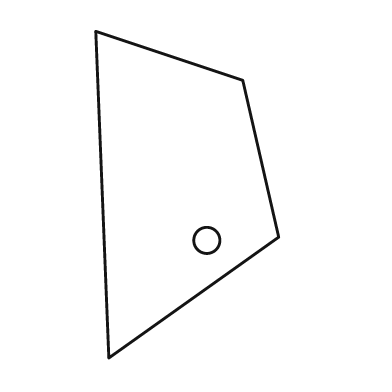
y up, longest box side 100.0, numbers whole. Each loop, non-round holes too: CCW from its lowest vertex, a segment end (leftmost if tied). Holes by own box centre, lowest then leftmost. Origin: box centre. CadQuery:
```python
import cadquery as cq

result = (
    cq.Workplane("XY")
    .moveTo(-24.0, -50.0)
    .lineTo(28.0, -13.0)
    .lineTo(17.0, 35.0)
    .lineTo(-28.0, 50.0)
    .close()
    .moveTo(6.0, -14.0)
    .circle(4.0)
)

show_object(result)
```